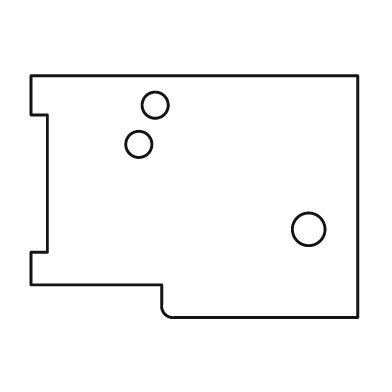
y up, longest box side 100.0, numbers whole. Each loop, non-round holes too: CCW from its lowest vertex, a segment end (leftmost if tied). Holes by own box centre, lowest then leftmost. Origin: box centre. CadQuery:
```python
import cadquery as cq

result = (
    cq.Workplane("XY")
    .moveTo(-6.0, -37.0)
    .lineTo(50.0, -37.0)
    .lineTo(50.0, 37.0)
    .lineTo(-50.0, 37.0)
    .lineTo(-50.0, 25.0)
    .lineTo(-45.0, 25.0)
    .lineTo(-45.0, -17.0)
    .lineTo(-50.0, -17.0)
    .lineTo(-50.0, -27.0)
    .lineTo(-10.0, -27.0)
    .lineTo(-10.0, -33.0)
    .threePointArc((-9.0, -36.0), (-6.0, -37.0))
    .close()
    .moveTo(35.0, -10.0)
    .circle(5.0)
    .moveTo(-17.0, 16.0)
    .circle(4.0)
    .moveTo(-12.0, 28.0)
    .circle(4.0)
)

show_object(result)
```